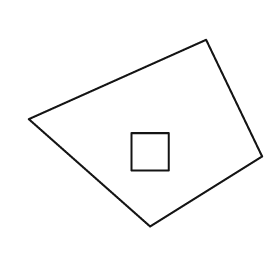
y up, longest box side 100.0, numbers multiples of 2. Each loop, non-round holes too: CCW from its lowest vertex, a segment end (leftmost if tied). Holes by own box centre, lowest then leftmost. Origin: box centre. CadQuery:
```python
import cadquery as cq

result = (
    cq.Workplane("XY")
    .moveTo(2.0, -40.0)
    .lineTo(50.0, -10.0)
    .lineTo(26.0, 40.0)
    .lineTo(-50.0, 6.0)
    .close()
    .moveTo(-6.0, -16.0)
    .lineTo(10.0, -16.0)
    .lineTo(10.0, 0.0)
    .lineTo(-6.0, 0.0)
    .close()
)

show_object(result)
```